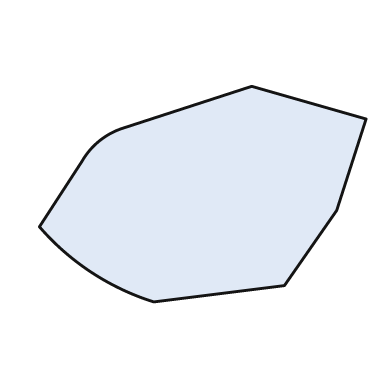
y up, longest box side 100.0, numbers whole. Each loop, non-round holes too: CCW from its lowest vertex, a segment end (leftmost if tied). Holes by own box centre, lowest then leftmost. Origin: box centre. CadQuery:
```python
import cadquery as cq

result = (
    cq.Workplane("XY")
    .moveTo(-15.0, -33.0)
    .lineTo(25.0, -28.0)
    .lineTo(41.0, -5.0)
    .lineTo(50.0, 23.0)
    .lineTo(15.0, 33.0)
    .lineTo(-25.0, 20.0)
    .threePointArc((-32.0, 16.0), (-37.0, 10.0))
    .lineTo(-50.0, -10.0)
    .threePointArc((-34.0, -24.0), (-15.0, -33.0))
    .close()
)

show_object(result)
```